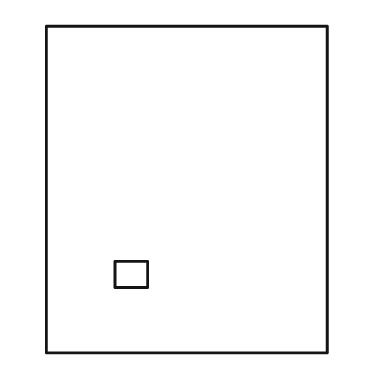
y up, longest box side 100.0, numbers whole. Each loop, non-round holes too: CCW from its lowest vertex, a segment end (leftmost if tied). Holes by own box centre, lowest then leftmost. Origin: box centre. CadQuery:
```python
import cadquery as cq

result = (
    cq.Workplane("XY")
    .moveTo(-43.0, -50.0)
    .lineTo(43.0, -50.0)
    .lineTo(43.0, 50.0)
    .lineTo(-43.0, 50.0)
    .close()
    .moveTo(-22.0, -30.0)
    .lineTo(-12.0, -30.0)
    .lineTo(-12.0, -22.0)
    .lineTo(-22.0, -22.0)
    .close()
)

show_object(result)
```